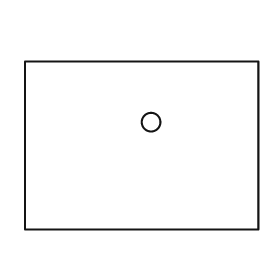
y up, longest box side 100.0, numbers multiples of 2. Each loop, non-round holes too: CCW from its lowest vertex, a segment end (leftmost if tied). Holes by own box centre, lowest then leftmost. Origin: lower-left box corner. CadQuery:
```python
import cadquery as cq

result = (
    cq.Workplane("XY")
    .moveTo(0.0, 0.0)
    .lineTo(100.0, 0.0)
    .lineTo(100.0, 72.0)
    .lineTo(0.0, 72.0)
    .close()
    .moveTo(54.0, 46.0)
    .circle(4.0)
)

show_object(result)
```